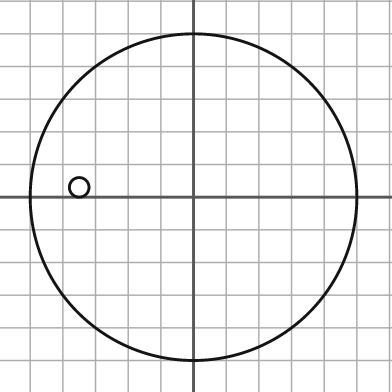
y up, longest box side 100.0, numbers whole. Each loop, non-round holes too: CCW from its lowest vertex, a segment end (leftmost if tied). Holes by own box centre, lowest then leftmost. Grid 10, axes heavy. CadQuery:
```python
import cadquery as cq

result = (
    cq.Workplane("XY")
    .moveTo(0.0, 0.0)
    .circle(50.0)
    .moveTo(-35.0, 3.0)
    .circle(3.0)
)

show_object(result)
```